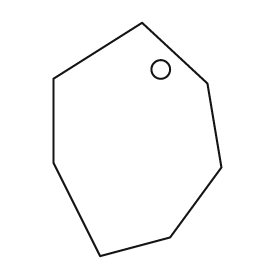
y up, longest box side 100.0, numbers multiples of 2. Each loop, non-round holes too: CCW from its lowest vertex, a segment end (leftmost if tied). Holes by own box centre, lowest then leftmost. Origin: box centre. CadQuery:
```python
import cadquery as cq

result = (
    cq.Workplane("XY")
    .moveTo(-16.0, -50.0)
    .lineTo(14.0, -42.0)
    .lineTo(36.0, -12.0)
    .lineTo(30.0, 24.0)
    .lineTo(2.0, 50.0)
    .lineTo(-36.0, 26.0)
    .lineTo(-36.0, -10.0)
    .close()
    .moveTo(10.0, 30.0)
    .circle(4.0)
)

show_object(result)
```